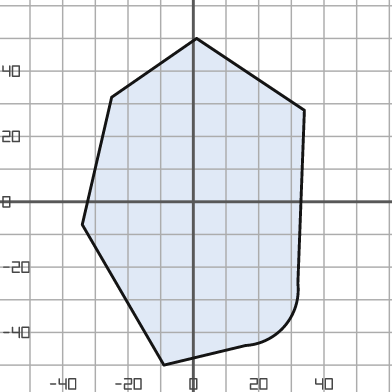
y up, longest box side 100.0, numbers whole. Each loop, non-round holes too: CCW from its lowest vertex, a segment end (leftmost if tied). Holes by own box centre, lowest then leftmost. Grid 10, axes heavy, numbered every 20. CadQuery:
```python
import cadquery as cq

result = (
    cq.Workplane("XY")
    .moveTo(-9.0, -50.0)
    .lineTo(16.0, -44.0)
    .threePointArc((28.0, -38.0), (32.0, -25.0))
    .lineTo(34.0, 28.0)
    .lineTo(1.0, 50.0)
    .lineTo(-25.0, 32.0)
    .lineTo(-34.0, -7.0)
    .close()
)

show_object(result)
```